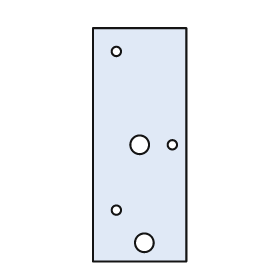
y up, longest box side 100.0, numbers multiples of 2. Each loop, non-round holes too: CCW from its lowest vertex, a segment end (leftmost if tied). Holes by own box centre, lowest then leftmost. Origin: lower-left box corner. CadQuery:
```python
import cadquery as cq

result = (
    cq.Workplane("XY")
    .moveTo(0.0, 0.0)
    .lineTo(40.0, 0.0)
    .lineTo(40.0, 100.0)
    .lineTo(0.0, 100.0)
    .close()
    .moveTo(22.0, 8.0)
    .circle(4.0)
    .moveTo(10.0, 22.0)
    .circle(2.0)
    .moveTo(20.0, 50.0)
    .circle(4.0)
    .moveTo(34.0, 50.0)
    .circle(2.0)
    .moveTo(10.0, 90.0)
    .circle(2.0)
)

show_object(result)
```